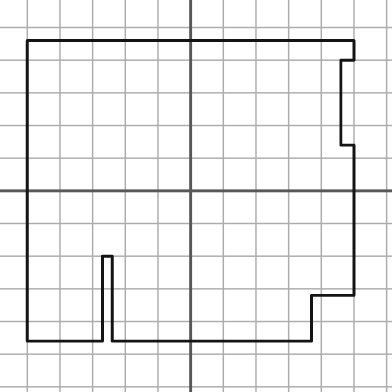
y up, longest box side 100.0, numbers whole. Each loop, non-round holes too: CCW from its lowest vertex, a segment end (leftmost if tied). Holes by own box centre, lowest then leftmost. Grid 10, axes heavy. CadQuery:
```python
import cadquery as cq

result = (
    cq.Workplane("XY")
    .moveTo(-50.0, -46.0)
    .lineTo(-27.0, -46.0)
    .lineTo(-27.0, -20.0)
    .lineTo(-24.0, -20.0)
    .lineTo(-24.0, -46.0)
    .lineTo(37.0, -46.0)
    .lineTo(37.0, -32.0)
    .lineTo(50.0, -32.0)
    .lineTo(50.0, 14.0)
    .lineTo(46.0, 14.0)
    .lineTo(46.0, 40.0)
    .lineTo(50.0, 40.0)
    .lineTo(50.0, 46.0)
    .lineTo(-50.0, 46.0)
    .close()
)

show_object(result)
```